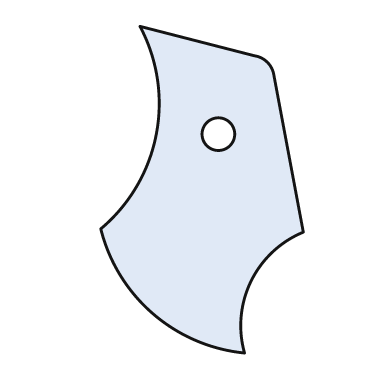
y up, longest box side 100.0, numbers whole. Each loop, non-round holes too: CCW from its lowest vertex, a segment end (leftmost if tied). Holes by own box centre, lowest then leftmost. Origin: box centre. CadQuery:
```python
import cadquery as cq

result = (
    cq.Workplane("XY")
    .moveTo(13.0, -50.0)
    .threePointArc((15.0, -28.0), (31.0, -13.0))
    .lineTo(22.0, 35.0)
    .threePointArc((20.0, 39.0), (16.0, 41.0))
    .lineTo(-19.0, 50.0)
    .threePointArc((-14.0, 17.0), (-31.0, -12.0))
    .threePointArc((-15.0, -38.0), (13.0, -50.0))
    .close()
    .moveTo(5.0, 17.0)
    .circle(5.0)
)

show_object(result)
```